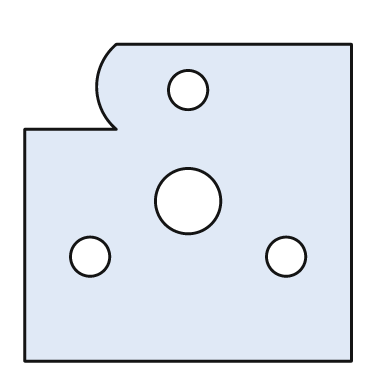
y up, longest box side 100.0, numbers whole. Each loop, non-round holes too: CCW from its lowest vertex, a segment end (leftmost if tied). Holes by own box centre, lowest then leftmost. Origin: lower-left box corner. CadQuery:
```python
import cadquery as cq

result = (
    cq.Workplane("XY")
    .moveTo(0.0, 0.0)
    .lineTo(100.0, 0.0)
    .lineTo(100.0, 97.0)
    .lineTo(28.0, 97.0)
    .threePointArc((22.0, 84.0), (28.0, 71.0))
    .lineTo(0.0, 71.0)
    .close()
    .moveTo(20.0, 32.0)
    .circle(6.0)
    .moveTo(80.0, 32.0)
    .circle(6.0)
    .moveTo(50.0, 49.0)
    .circle(10.0)
    .moveTo(50.0, 83.0)
    .circle(6.0)
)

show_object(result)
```